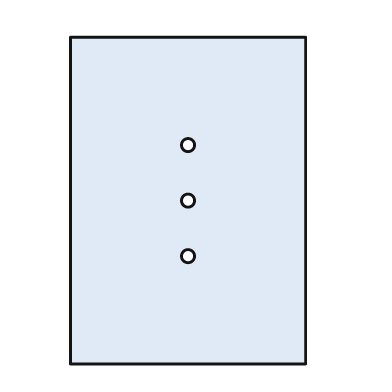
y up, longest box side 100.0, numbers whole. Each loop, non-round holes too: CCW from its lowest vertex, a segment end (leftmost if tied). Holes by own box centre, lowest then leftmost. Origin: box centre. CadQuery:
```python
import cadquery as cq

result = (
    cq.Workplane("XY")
    .moveTo(-36.0, -50.0)
    .lineTo(36.0, -50.0)
    .lineTo(36.0, 50.0)
    .lineTo(-36.0, 50.0)
    .close()
    .moveTo(0.0, -17.0)
    .circle(2.0)
    .moveTo(0.0, 0.0)
    .circle(2.0)
    .moveTo(0.0, 17.0)
    .circle(2.0)
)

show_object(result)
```